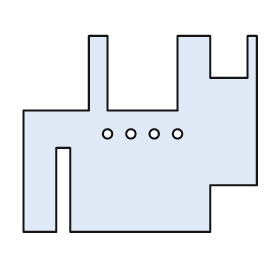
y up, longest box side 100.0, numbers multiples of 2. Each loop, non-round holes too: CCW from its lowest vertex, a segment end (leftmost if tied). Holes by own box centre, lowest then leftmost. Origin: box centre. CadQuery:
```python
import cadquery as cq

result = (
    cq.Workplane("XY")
    .moveTo(-50.0, -42.0)
    .lineTo(-36.0, -42.0)
    .lineTo(-36.0, -6.0)
    .lineTo(-30.0, -6.0)
    .lineTo(-30.0, -42.0)
    .lineTo(30.0, -42.0)
    .lineTo(30.0, -22.0)
    .lineTo(50.0, -22.0)
    .lineTo(50.0, 42.0)
    .lineTo(46.0, 42.0)
    .lineTo(46.0, 24.0)
    .lineTo(30.0, 24.0)
    .lineTo(30.0, 42.0)
    .lineTo(16.0, 42.0)
    .lineTo(16.0, 10.0)
    .lineTo(-14.0, 10.0)
    .lineTo(-14.0, 42.0)
    .lineTo(-22.0, 42.0)
    .lineTo(-22.0, 10.0)
    .lineTo(-50.0, 10.0)
    .close()
    .moveTo(-14.0, 0.0)
    .circle(2.0)
    .moveTo(-4.0, 0.0)
    .circle(2.0)
    .moveTo(6.0, 0.0)
    .circle(2.0)
    .moveTo(16.0, 0.0)
    .circle(2.0)
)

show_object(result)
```